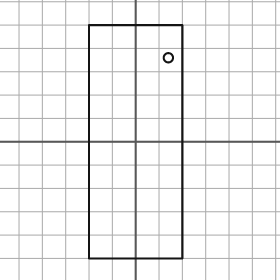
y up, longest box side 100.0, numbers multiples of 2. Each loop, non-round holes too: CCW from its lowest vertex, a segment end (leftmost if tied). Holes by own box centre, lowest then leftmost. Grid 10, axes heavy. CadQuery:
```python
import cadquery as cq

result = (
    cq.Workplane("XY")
    .moveTo(-20.0, -50.0)
    .lineTo(20.0, -50.0)
    .lineTo(20.0, 50.0)
    .lineTo(-20.0, 50.0)
    .close()
    .moveTo(14.0, 36.0)
    .circle(2.0)
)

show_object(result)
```